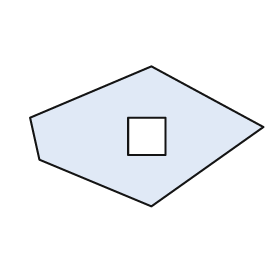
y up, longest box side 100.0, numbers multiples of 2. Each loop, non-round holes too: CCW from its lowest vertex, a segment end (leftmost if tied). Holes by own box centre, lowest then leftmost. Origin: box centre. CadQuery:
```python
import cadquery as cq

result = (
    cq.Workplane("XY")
    .moveTo(2.0, -30.0)
    .lineTo(50.0, 4.0)
    .lineTo(2.0, 30.0)
    .lineTo(-50.0, 8.0)
    .lineTo(-46.0, -10.0)
    .close()
    .moveTo(-8.0, -8.0)
    .lineTo(8.0, -8.0)
    .lineTo(8.0, 8.0)
    .lineTo(-8.0, 8.0)
    .close()
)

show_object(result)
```